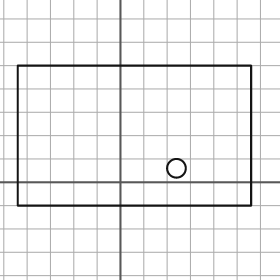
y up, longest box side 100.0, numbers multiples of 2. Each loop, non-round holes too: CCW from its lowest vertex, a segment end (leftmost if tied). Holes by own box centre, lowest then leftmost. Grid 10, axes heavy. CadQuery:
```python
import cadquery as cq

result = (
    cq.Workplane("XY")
    .moveTo(-44.0, -10.0)
    .lineTo(56.0, -10.0)
    .lineTo(56.0, 50.0)
    .lineTo(-44.0, 50.0)
    .close()
    .moveTo(24.0, 6.0)
    .circle(4.0)
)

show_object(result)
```